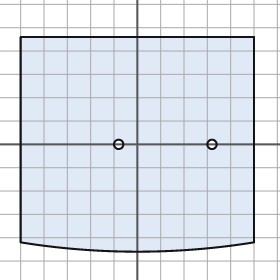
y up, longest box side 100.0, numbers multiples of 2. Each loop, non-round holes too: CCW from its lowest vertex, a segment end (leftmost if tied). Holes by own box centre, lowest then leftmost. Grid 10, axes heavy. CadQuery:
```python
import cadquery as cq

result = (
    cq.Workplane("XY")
    .moveTo(-50.0, -42.0)
    .threePointArc((0.0, -46.0), (50.0, -42.0))
    .lineTo(50.0, 46.0)
    .lineTo(-50.0, 46.0)
    .close()
    .moveTo(-8.0, 0.0)
    .circle(2.0)
    .moveTo(32.0, 0.0)
    .circle(2.0)
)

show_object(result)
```